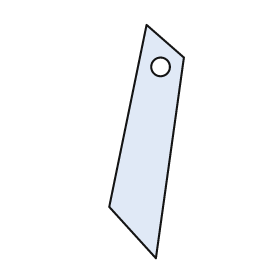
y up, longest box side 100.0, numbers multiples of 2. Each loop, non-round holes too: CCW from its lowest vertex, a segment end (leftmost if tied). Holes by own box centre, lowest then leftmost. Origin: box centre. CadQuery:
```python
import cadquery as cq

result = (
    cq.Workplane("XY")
    .moveTo(4.0, -50.0)
    .lineTo(16.0, 36.0)
    .lineTo(0.0, 50.0)
    .lineTo(-16.0, -28.0)
    .close()
    .moveTo(6.0, 32.0)
    .circle(4.0)
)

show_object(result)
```